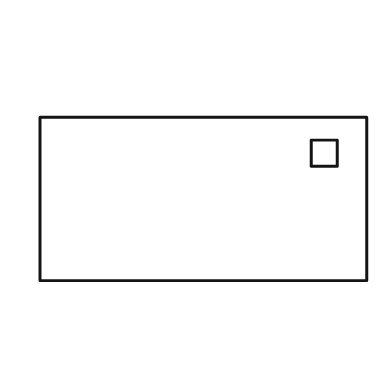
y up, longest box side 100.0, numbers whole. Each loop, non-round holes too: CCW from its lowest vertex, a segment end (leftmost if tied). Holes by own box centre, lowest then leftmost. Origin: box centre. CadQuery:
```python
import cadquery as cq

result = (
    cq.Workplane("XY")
    .moveTo(-50.0, -25.0)
    .lineTo(50.0, -25.0)
    .lineTo(50.0, 25.0)
    .lineTo(-50.0, 25.0)
    .close()
    .moveTo(33.0, 10.0)
    .lineTo(41.0, 10.0)
    .lineTo(41.0, 18.0)
    .lineTo(33.0, 18.0)
    .close()
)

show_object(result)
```